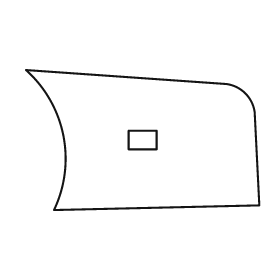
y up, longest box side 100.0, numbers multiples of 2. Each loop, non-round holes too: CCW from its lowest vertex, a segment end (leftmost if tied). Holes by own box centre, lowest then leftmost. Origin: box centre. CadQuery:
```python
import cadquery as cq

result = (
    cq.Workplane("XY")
    .moveTo(-38.0, -30.0)
    .lineTo(50.0, -28.0)
    .lineTo(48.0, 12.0)
    .threePointArc((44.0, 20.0), (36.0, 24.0))
    .lineTo(-50.0, 30.0)
    .threePointArc((-34.0, 2.0), (-38.0, -30.0))
    .close()
    .moveTo(-6.0, -4.0)
    .lineTo(6.0, -4.0)
    .lineTo(6.0, 4.0)
    .lineTo(-6.0, 4.0)
    .close()
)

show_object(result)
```